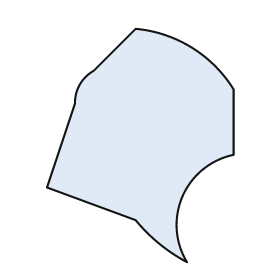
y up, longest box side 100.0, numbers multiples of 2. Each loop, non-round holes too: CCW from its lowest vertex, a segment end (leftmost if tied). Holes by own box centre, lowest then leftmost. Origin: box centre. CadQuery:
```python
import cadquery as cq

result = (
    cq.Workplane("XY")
    .moveTo(20.0, -50.0)
    .threePointArc((18.0, -22.0), (40.0, -4.0))
    .lineTo(40.0, 24.0)
    .threePointArc((22.0, 42.0), (-2.0, 50.0))
    .lineTo(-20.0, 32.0)
    .threePointArc((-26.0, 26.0), (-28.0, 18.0))
    .lineTo(-40.0, -18.0)
    .lineTo(-2.0, -32.0)
    .threePointArc((8.0, -42.0), (20.0, -50.0))
    .close()
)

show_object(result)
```